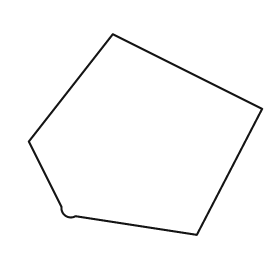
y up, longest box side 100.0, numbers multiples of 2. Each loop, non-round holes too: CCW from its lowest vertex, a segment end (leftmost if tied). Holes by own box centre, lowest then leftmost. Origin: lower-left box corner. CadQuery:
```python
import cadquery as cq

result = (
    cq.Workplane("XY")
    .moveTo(72.0, 0.0)
    .lineTo(100.0, 54.0)
    .lineTo(36.0, 86.0)
    .lineTo(0.0, 40.0)
    .lineTo(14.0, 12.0)
    .threePointArc((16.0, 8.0), (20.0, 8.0))
    .close()
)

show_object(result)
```